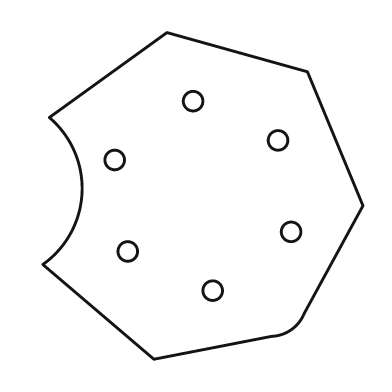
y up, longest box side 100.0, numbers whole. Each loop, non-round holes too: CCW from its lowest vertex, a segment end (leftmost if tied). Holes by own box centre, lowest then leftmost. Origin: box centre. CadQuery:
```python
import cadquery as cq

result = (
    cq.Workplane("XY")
    .moveTo(-15.0, -50.0)
    .lineTo(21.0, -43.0)
    .threePointArc((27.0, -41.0), (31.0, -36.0))
    .lineTo(49.0, -3.0)
    .lineTo(32.0, 38.0)
    .lineTo(-11.0, 50.0)
    .lineTo(-47.0, 24.0)
    .threePointArc((-37.0, 1.0), (-49.0, -21.0))
    .close()
    .moveTo(3.0, -29.0)
    .circle(3.0)
    .moveTo(-23.0, -17.0)
    .circle(3.0)
    .moveTo(27.0, -11.0)
    .circle(3.0)
    .moveTo(-27.0, 11.0)
    .circle(3.0)
    .moveTo(23.0, 17.0)
    .circle(3.0)
    .moveTo(-3.0, 29.0)
    .circle(3.0)
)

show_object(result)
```